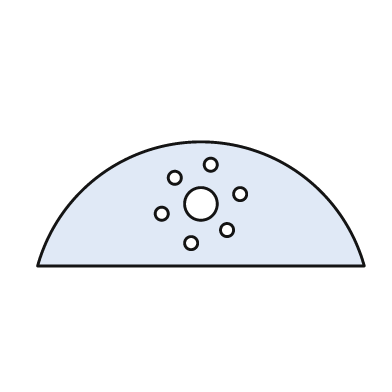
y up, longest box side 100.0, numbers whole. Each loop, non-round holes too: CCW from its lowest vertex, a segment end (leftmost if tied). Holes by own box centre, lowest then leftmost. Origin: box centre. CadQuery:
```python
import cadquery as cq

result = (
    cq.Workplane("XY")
    .moveTo(-50.0, -19.0)
    .lineTo(50.0, -19.0)
    .threePointArc((0.0, 19.0), (-50.0, -19.0))
    .close()
    .moveTo(-3.0, -12.0)
    .circle(2.0)
    .moveTo(8.0, -8.0)
    .circle(2.0)
    .moveTo(-12.0, -3.0)
    .circle(2.0)
    .moveTo(0.0, 0.0)
    .circle(5.0)
    .moveTo(12.0, 3.0)
    .circle(2.0)
    .moveTo(-8.0, 8.0)
    .circle(2.0)
    .moveTo(3.0, 12.0)
    .circle(2.0)
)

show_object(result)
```